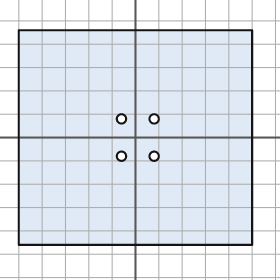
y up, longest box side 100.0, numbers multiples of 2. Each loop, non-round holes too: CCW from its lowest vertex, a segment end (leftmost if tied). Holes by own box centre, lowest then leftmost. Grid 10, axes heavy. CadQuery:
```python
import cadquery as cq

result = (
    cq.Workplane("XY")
    .moveTo(-50.0, -46.0)
    .lineTo(50.0, -46.0)
    .lineTo(50.0, 46.0)
    .lineTo(-50.0, 46.0)
    .close()
    .moveTo(-6.0, -8.0)
    .circle(2.0)
    .moveTo(8.0, -8.0)
    .circle(2.0)
    .moveTo(-6.0, 8.0)
    .circle(2.0)
    .moveTo(8.0, 8.0)
    .circle(2.0)
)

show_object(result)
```